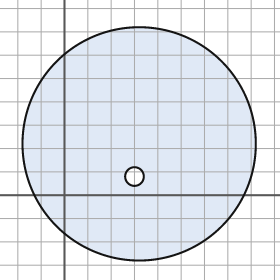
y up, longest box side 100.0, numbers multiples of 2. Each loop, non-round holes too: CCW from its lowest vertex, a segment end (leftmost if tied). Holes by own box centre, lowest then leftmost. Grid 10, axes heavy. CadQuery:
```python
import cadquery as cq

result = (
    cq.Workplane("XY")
    .moveTo(32.0, 22.0)
    .circle(50.0)
    .moveTo(30.0, 8.0)
    .circle(4.0)
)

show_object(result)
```